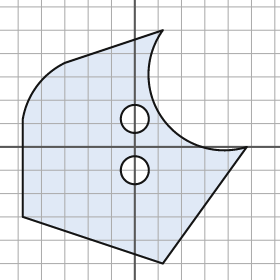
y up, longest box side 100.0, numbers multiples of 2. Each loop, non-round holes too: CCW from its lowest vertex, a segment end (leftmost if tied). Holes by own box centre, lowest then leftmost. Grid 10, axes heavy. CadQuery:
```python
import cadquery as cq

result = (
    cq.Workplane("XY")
    .moveTo(12.0, -50.0)
    .lineTo(48.0, 0.0)
    .threePointArc((12.0, 12.0), (12.0, 50.0))
    .lineTo(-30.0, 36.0)
    .threePointArc((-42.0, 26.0), (-48.0, 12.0))
    .lineTo(-48.0, -30.0)
    .close()
    .moveTo(0.0, -10.0)
    .circle(6.0)
    .moveTo(0.0, 12.0)
    .circle(6.0)
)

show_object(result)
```